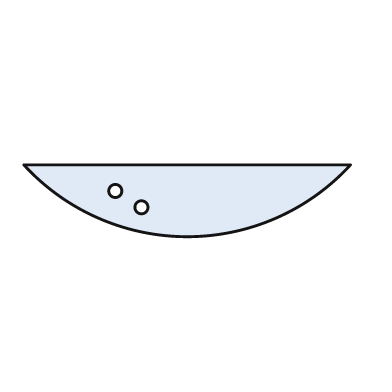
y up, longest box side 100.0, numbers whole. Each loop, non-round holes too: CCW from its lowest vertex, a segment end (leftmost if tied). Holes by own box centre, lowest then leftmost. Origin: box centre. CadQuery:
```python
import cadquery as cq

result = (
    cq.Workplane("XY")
    .moveTo(-50.0, 11.0)
    .threePointArc((0.0, -11.0), (50.0, 11.0))
    .close()
    .moveTo(-14.0, -2.0)
    .circle(2.0)
    .moveTo(-22.0, 3.0)
    .circle(2.0)
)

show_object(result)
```